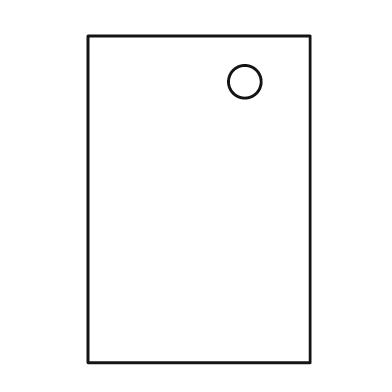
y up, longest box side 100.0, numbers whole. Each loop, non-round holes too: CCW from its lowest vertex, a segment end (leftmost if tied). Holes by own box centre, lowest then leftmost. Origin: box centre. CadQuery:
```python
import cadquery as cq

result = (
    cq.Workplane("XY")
    .moveTo(-34.0, -50.0)
    .lineTo(34.0, -50.0)
    .lineTo(34.0, 50.0)
    .lineTo(-34.0, 50.0)
    .close()
    .moveTo(14.0, 36.0)
    .circle(5.0)
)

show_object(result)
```